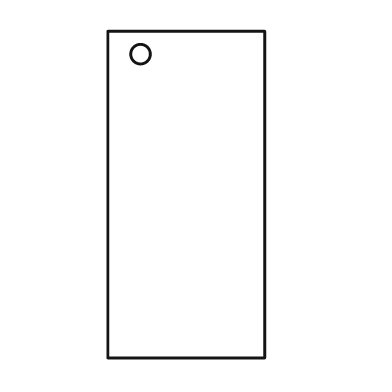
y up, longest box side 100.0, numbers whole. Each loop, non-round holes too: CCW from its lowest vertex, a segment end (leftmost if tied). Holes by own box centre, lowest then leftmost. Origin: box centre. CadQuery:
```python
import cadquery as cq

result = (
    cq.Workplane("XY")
    .moveTo(-24.0, -50.0)
    .lineTo(24.0, -50.0)
    .lineTo(24.0, 50.0)
    .lineTo(-24.0, 50.0)
    .close()
    .moveTo(-14.0, 43.0)
    .circle(3.0)
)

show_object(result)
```